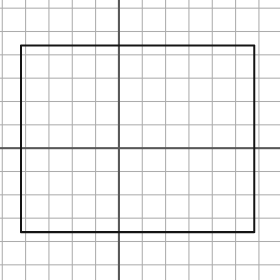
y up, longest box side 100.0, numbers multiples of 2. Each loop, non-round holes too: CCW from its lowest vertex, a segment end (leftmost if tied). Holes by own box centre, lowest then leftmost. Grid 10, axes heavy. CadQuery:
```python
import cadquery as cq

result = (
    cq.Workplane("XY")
    .moveTo(-42.0, -36.0)
    .lineTo(58.0, -36.0)
    .lineTo(58.0, 44.0)
    .lineTo(-42.0, 44.0)
    .close()
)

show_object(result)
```